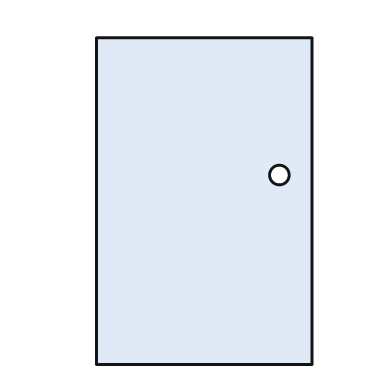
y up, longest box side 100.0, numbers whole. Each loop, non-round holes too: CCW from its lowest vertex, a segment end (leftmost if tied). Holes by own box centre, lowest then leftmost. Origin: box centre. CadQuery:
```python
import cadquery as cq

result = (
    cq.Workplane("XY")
    .moveTo(-33.0, -50.0)
    .lineTo(33.0, -50.0)
    .lineTo(33.0, 50.0)
    .lineTo(-33.0, 50.0)
    .close()
    .moveTo(23.0, 8.0)
    .circle(3.0)
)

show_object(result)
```